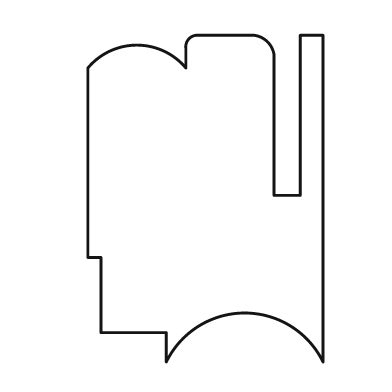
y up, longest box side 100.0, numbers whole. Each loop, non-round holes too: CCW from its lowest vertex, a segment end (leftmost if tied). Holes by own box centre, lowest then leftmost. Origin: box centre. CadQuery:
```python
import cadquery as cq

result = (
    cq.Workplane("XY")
    .moveTo(-12.0, -50.0)
    .threePointArc((12.0, -35.0), (36.0, -50.0))
    .lineTo(36.0, 50.0)
    .lineTo(29.0, 50.0)
    .lineTo(29.0, 1.0)
    .lineTo(21.0, 1.0)
    .lineTo(21.0, 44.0)
    .threePointArc((19.0, 48.0), (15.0, 50.0))
    .lineTo(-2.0, 50.0)
    .threePointArc((-5.0, 49.0), (-6.0, 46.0))
    .lineTo(-6.0, 40.0)
    .threePointArc((-21.0, 47.0), (-36.0, 40.0))
    .lineTo(-36.0, -18.0)
    .lineTo(-32.0, -18.0)
    .lineTo(-32.0, -41.0)
    .lineTo(-12.0, -41.0)
    .close()
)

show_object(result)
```